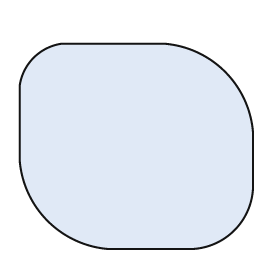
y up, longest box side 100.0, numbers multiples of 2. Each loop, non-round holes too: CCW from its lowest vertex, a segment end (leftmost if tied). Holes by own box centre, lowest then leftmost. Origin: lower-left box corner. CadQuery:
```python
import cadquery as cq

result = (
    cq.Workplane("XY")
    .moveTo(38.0, 0.0)
    .lineTo(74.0, 0.0)
    .threePointArc((92.0, 8.0), (100.0, 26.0))
    .lineTo(100.0, 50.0)
    .threePointArc((88.0, 76.0), (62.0, 88.0))
    .lineTo(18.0, 88.0)
    .threePointArc((6.0, 82.0), (0.0, 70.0))
    .lineTo(0.0, 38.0)
    .threePointArc((12.0, 12.0), (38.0, 0.0))
    .close()
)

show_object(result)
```